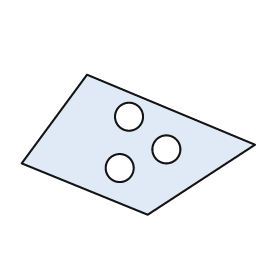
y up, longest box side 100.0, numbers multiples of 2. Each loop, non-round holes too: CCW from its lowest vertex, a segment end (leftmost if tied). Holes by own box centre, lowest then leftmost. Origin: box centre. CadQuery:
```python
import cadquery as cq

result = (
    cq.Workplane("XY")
    .moveTo(4.0, -30.0)
    .lineTo(50.0, 0.0)
    .lineTo(-22.0, 30.0)
    .lineTo(-50.0, -8.0)
    .close()
    .moveTo(-8.0, -10.0)
    .circle(6.0)
    .moveTo(12.0, -2.0)
    .circle(6.0)
    .moveTo(-4.0, 12.0)
    .circle(6.0)
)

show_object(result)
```